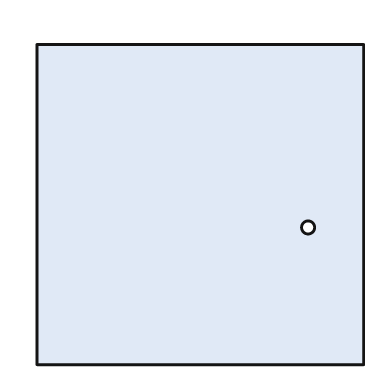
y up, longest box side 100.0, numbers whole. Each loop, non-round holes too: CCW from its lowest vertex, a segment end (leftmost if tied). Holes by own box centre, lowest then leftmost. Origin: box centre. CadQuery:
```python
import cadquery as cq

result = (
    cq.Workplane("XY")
    .moveTo(-50.0, -49.0)
    .lineTo(50.0, -49.0)
    .lineTo(50.0, 49.0)
    .lineTo(-50.0, 49.0)
    .close()
    .moveTo(33.0, -7.0)
    .circle(2.0)
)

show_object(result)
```